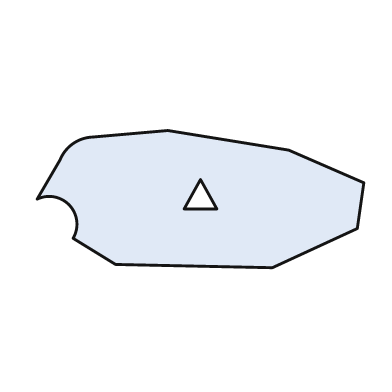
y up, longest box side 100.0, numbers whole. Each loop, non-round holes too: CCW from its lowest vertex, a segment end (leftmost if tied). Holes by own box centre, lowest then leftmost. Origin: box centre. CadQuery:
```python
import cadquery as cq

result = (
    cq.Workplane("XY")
    .moveTo(22.0, -21.0)
    .lineTo(48.0, -9.0)
    .lineTo(50.0, 5.0)
    .lineTo(27.0, 15.0)
    .lineTo(-10.0, 21.0)
    .lineTo(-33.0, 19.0)
    .threePointArc((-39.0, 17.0), (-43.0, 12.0))
    .lineTo(-50.0, 0.0)
    .threePointArc((-40.0, -2.0), (-39.0, -12.0))
    .lineTo(-26.0, -20.0)
    .close()
    .moveTo(-5.0, -3.0)
    .lineTo(5.0, -3.0)
    .lineTo(0.0, 6.0)
    .close()
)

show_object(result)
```